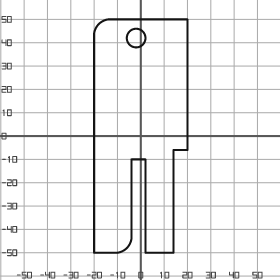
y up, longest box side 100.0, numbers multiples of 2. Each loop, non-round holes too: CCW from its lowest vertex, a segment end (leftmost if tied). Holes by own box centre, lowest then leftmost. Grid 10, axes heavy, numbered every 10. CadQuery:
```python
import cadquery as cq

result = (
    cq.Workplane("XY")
    .moveTo(-20.0, -50.0)
    .lineTo(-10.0, -50.0)
    .threePointArc((-6.0, -48.0), (-4.0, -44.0))
    .lineTo(-4.0, -10.0)
    .lineTo(2.0, -10.0)
    .lineTo(2.0, -50.0)
    .lineTo(14.0, -50.0)
    .lineTo(14.0, -6.0)
    .lineTo(20.0, -6.0)
    .lineTo(20.0, 50.0)
    .lineTo(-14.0, 50.0)
    .threePointArc((-18.0, 48.0), (-20.0, 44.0))
    .close()
    .moveTo(-2.0, 42.0)
    .circle(4.0)
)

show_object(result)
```